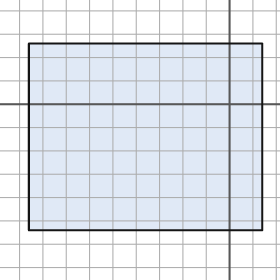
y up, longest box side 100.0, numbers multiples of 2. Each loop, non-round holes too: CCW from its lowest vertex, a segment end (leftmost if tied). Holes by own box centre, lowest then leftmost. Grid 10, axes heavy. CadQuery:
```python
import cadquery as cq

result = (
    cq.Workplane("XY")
    .moveTo(-86.0, -54.0)
    .lineTo(14.0, -54.0)
    .lineTo(14.0, 26.0)
    .lineTo(-86.0, 26.0)
    .close()
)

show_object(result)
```